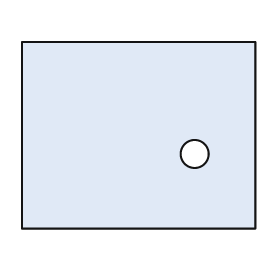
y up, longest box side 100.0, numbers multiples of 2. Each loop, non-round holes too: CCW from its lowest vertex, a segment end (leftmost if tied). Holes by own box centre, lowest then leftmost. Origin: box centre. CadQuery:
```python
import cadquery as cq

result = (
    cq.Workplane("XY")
    .moveTo(-50.0, -40.0)
    .lineTo(50.0, -40.0)
    .lineTo(50.0, 40.0)
    .lineTo(-50.0, 40.0)
    .close()
    .moveTo(24.0, -8.0)
    .circle(6.0)
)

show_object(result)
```